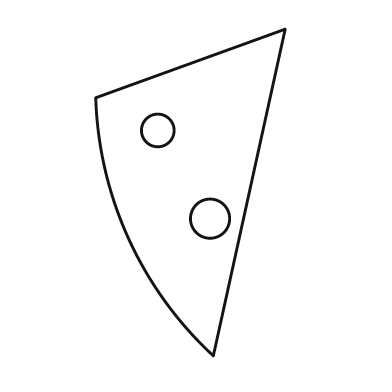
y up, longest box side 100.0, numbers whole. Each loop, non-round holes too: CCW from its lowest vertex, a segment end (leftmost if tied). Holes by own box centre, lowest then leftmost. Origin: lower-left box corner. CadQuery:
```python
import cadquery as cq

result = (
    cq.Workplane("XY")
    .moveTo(36.0, 0.0)
    .lineTo(58.0, 100.0)
    .lineTo(0.0, 79.0)
    .threePointArc((10.0, 36.0), (36.0, 0.0))
    .close()
    .moveTo(35.0, 42.0)
    .circle(6.0)
    .moveTo(19.0, 69.0)
    .circle(5.0)
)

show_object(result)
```